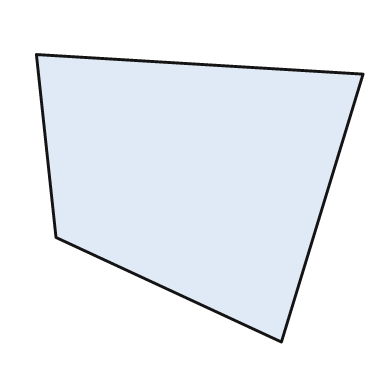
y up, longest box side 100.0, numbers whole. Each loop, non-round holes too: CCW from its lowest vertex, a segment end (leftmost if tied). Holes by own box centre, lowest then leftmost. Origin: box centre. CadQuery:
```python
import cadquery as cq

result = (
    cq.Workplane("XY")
    .moveTo(25.0, -44.0)
    .lineTo(50.0, 38.0)
    .lineTo(-50.0, 44.0)
    .lineTo(-44.0, -12.0)
    .close()
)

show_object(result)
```